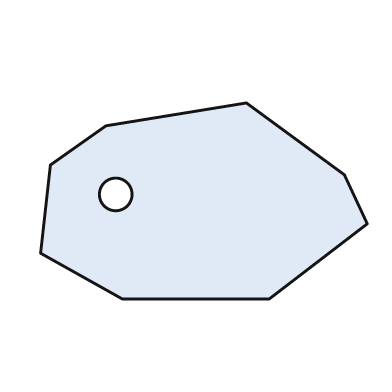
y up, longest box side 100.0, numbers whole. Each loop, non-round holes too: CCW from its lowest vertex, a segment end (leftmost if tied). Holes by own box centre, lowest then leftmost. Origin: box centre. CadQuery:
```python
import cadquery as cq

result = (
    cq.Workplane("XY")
    .moveTo(-25.0, -30.0)
    .lineTo(20.0, -30.0)
    .lineTo(50.0, -7.0)
    .lineTo(43.0, 8.0)
    .lineTo(13.0, 30.0)
    .lineTo(-30.0, 23.0)
    .lineTo(-47.0, 11.0)
    .lineTo(-50.0, -16.0)
    .close()
    .moveTo(-27.0, 2.0)
    .circle(5.0)
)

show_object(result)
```